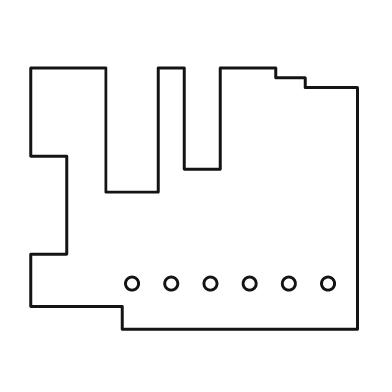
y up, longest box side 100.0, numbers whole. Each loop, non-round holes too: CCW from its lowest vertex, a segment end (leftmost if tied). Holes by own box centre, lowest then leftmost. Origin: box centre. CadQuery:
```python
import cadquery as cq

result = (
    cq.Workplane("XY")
    .moveTo(-22.0, -40.0)
    .lineTo(50.0, -40.0)
    .lineTo(50.0, 34.0)
    .lineTo(34.0, 34.0)
    .lineTo(34.0, 37.0)
    .lineTo(25.0, 37.0)
    .lineTo(25.0, 40.0)
    .lineTo(8.0, 40.0)
    .lineTo(8.0, 9.0)
    .lineTo(-3.0, 9.0)
    .lineTo(-3.0, 40.0)
    .lineTo(-11.0, 40.0)
    .lineTo(-11.0, 2.0)
    .lineTo(-27.0, 2.0)
    .lineTo(-27.0, 40.0)
    .lineTo(-50.0, 40.0)
    .lineTo(-50.0, 13.0)
    .lineTo(-39.0, 13.0)
    .lineTo(-39.0, -17.0)
    .lineTo(-50.0, -17.0)
    .lineTo(-50.0, -33.0)
    .lineTo(-22.0, -33.0)
    .close()
    .moveTo(-19.0, -26.0)
    .circle(2.0)
    .moveTo(-7.0, -26.0)
    .circle(2.0)
    .moveTo(5.0, -26.0)
    .circle(2.0)
    .moveTo(17.0, -26.0)
    .circle(2.0)
    .moveTo(29.0, -26.0)
    .circle(2.0)
    .moveTo(41.0, -26.0)
    .circle(2.0)
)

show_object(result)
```